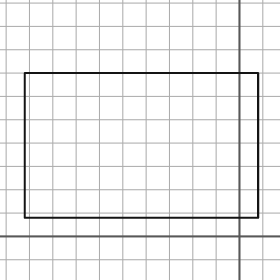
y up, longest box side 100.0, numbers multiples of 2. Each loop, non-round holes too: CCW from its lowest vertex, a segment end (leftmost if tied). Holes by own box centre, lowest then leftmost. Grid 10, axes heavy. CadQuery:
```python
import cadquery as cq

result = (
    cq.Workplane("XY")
    .moveTo(-92.0, 8.0)
    .lineTo(8.0, 8.0)
    .lineTo(8.0, 70.0)
    .lineTo(-92.0, 70.0)
    .close()
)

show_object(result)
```